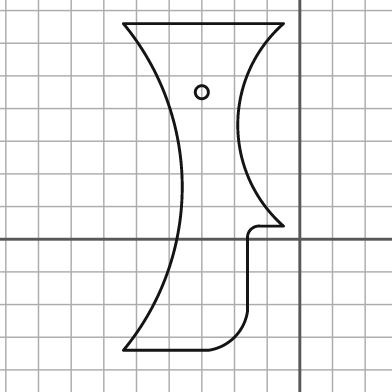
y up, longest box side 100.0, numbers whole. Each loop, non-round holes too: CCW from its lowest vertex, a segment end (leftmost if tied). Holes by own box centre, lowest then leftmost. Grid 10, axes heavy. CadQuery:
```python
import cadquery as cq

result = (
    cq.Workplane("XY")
    .moveTo(-54.0, -34.0)
    .lineTo(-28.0, -34.0)
    .threePointArc((-20.0, -30.0), (-16.0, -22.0))
    .lineTo(-16.0, 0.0)
    .threePointArc((-15.0, 3.0), (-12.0, 4.0))
    .lineTo(-5.0, 4.0)
    .threePointArc((-19.0, 35.0), (-5.0, 66.0))
    .lineTo(-54.0, 66.0)
    .threePointArc((-36.0, 16.0), (-54.0, -34.0))
    .close()
    .moveTo(-30.0, 45.0)
    .circle(2.0)
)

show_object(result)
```